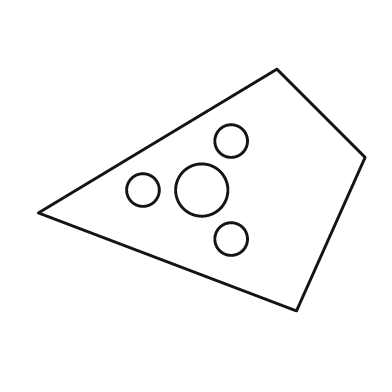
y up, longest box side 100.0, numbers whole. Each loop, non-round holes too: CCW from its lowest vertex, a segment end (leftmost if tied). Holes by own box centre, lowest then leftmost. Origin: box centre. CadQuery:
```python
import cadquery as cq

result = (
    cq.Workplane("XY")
    .moveTo(29.0, -37.0)
    .lineTo(50.0, 10.0)
    .lineTo(23.0, 37.0)
    .lineTo(-50.0, -7.0)
    .close()
    .moveTo(9.0, -15.0)
    .circle(5.0)
    .moveTo(-18.0, 0.0)
    .circle(5.0)
    .moveTo(0.0, 0.0)
    .circle(8.0)
    .moveTo(9.0, 15.0)
    .circle(5.0)
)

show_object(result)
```